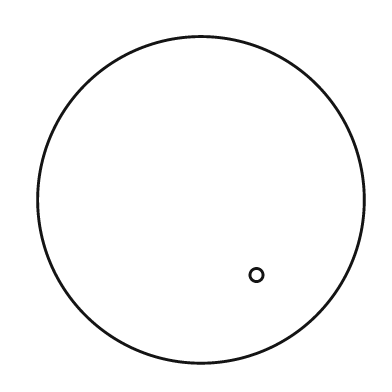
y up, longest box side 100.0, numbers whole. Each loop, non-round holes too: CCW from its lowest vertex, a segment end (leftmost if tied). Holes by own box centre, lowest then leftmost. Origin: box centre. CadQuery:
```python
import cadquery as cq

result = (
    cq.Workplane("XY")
    .moveTo(0.0, 0.0)
    .circle(50.0)
    .moveTo(17.0, -23.0)
    .circle(2.0)
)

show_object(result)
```